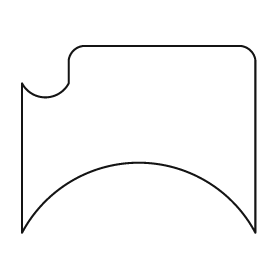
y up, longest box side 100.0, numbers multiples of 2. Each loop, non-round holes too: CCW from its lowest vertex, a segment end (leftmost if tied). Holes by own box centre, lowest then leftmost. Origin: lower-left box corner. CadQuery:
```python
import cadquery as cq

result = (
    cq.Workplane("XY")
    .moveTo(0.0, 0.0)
    .threePointArc((50.0, 30.0), (100.0, 0.0))
    .lineTo(100.0, 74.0)
    .threePointArc((98.0, 78.0), (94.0, 80.0))
    .lineTo(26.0, 80.0)
    .threePointArc((22.0, 78.0), (20.0, 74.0))
    .lineTo(20.0, 64.0)
    .threePointArc((10.0, 58.0), (0.0, 64.0))
    .close()
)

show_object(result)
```